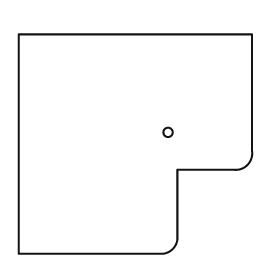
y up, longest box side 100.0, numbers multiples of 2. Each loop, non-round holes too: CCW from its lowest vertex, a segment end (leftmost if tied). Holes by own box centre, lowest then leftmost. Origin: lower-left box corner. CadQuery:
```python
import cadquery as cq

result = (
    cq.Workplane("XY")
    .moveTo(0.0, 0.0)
    .lineTo(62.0, 0.0)
    .threePointArc((66.0, 2.0), (68.0, 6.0))
    .lineTo(68.0, 36.0)
    .lineTo(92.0, 36.0)
    .threePointArc((98.0, 38.0), (100.0, 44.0))
    .lineTo(100.0, 94.0)
    .lineTo(0.0, 94.0)
    .close()
    .moveTo(64.0, 52.0)
    .circle(2.0)
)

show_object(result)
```